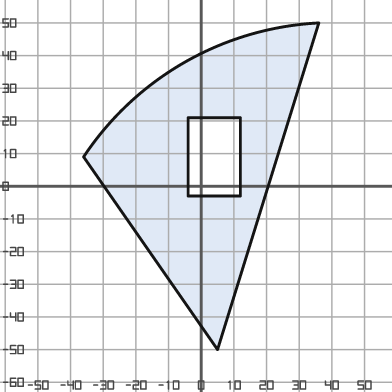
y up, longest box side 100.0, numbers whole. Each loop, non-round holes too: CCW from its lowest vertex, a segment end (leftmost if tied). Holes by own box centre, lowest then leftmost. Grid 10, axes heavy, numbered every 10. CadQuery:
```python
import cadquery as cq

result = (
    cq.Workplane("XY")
    .moveTo(5.0, -50.0)
    .lineTo(36.0, 50.0)
    .threePointArc((-5.0, 38.0), (-36.0, 9.0))
    .close()
    .moveTo(-4.0, -3.0)
    .lineTo(12.0, -3.0)
    .lineTo(12.0, 21.0)
    .lineTo(-4.0, 21.0)
    .close()
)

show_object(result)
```